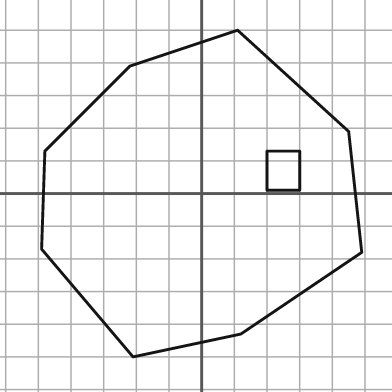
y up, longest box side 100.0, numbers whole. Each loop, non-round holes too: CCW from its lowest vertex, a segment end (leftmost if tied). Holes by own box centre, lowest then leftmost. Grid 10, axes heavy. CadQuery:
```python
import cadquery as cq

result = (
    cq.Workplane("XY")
    .moveTo(-21.0, -50.0)
    .lineTo(12.0, -43.0)
    .lineTo(49.0, -18.0)
    .lineTo(45.0, 19.0)
    .lineTo(11.0, 50.0)
    .lineTo(-22.0, 39.0)
    .lineTo(-48.0, 13.0)
    .lineTo(-49.0, -17.0)
    .close()
    .moveTo(20.0, 1.0)
    .lineTo(30.0, 1.0)
    .lineTo(30.0, 13.0)
    .lineTo(20.0, 13.0)
    .close()
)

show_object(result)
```